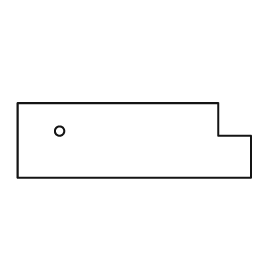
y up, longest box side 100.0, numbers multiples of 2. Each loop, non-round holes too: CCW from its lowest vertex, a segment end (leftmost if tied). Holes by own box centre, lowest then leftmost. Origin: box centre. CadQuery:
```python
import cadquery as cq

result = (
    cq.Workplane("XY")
    .moveTo(-50.0, -16.0)
    .lineTo(50.0, -16.0)
    .lineTo(50.0, 2.0)
    .lineTo(36.0, 2.0)
    .lineTo(36.0, 16.0)
    .lineTo(-50.0, 16.0)
    .close()
    .moveTo(-32.0, 4.0)
    .circle(2.0)
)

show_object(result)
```